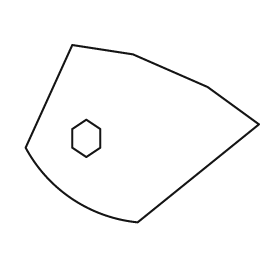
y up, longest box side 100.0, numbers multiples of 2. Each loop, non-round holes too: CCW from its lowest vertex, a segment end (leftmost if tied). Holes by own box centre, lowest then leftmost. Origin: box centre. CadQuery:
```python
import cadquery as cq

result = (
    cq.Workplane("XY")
    .moveTo(-2.0, -38.0)
    .lineTo(50.0, 4.0)
    .lineTo(28.0, 20.0)
    .lineTo(-4.0, 34.0)
    .lineTo(-30.0, 38.0)
    .lineTo(-50.0, -6.0)
    .threePointArc((-30.0, -28.0), (-2.0, -38.0))
    .close()
    .moveTo(-24.0, -10.0)
    .lineTo(-18.0, -6.0)
    .lineTo(-18.0, 2.0)
    .lineTo(-24.0, 6.0)
    .lineTo(-30.0, 2.0)
    .lineTo(-30.0, -6.0)
    .close()
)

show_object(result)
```